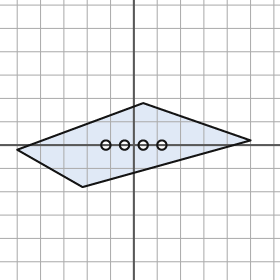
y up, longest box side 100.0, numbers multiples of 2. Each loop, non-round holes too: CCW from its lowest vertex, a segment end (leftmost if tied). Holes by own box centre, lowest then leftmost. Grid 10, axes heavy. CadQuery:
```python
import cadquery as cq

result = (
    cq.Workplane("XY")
    .moveTo(-22.0, -18.0)
    .lineTo(50.0, 2.0)
    .lineTo(4.0, 18.0)
    .lineTo(-50.0, -2.0)
    .close()
    .moveTo(-12.0, 0.0)
    .circle(2.0)
    .moveTo(-4.0, 0.0)
    .circle(2.0)
    .moveTo(4.0, 0.0)
    .circle(2.0)
    .moveTo(12.0, 0.0)
    .circle(2.0)
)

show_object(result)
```